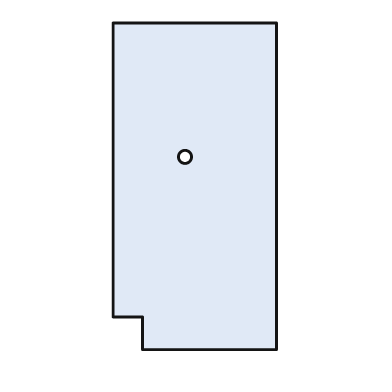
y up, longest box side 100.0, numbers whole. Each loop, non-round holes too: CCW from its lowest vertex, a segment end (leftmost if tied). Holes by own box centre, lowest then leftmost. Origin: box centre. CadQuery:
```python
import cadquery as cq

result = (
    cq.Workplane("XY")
    .moveTo(-16.0, -50.0)
    .lineTo(25.0, -50.0)
    .lineTo(25.0, 50.0)
    .lineTo(-25.0, 50.0)
    .lineTo(-25.0, -40.0)
    .lineTo(-16.0, -40.0)
    .close()
    .moveTo(-3.0, 9.0)
    .circle(2.0)
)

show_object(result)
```